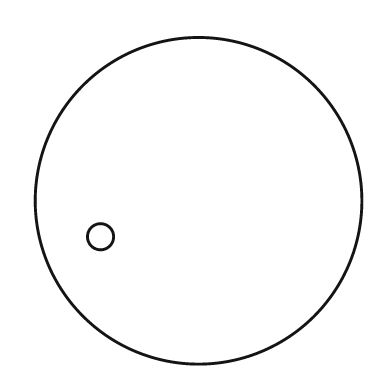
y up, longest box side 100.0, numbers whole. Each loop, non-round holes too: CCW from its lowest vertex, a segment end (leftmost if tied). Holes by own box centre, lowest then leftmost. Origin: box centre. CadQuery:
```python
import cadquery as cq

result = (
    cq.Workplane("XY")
    .moveTo(0.0, 0.0)
    .circle(50.0)
    .moveTo(-30.0, -11.0)
    .circle(4.0)
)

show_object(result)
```